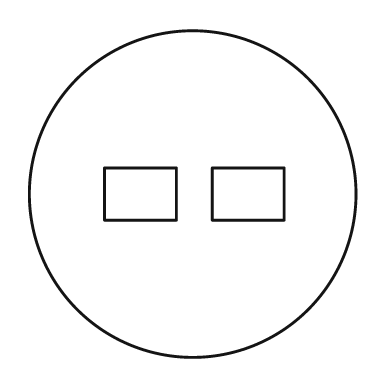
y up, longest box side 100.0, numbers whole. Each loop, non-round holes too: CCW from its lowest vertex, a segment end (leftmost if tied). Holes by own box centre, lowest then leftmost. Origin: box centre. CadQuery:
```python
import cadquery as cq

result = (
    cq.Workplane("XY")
    .moveTo(0.0, 0.0)
    .circle(50.0)
    .moveTo(-27.0, -8.0)
    .lineTo(-5.0, -8.0)
    .lineTo(-5.0, 8.0)
    .lineTo(-27.0, 8.0)
    .close()
    .moveTo(6.0, -8.0)
    .lineTo(28.0, -8.0)
    .lineTo(28.0, 8.0)
    .lineTo(6.0, 8.0)
    .close()
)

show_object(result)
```